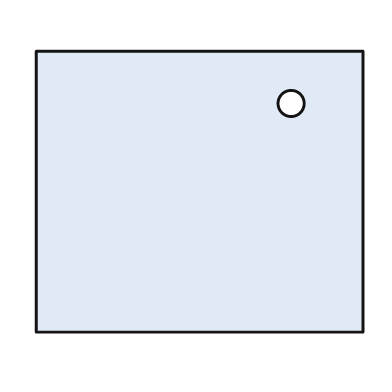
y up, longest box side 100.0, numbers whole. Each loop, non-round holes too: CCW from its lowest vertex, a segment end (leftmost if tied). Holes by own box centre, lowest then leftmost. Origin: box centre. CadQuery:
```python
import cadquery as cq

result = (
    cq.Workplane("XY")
    .moveTo(-50.0, -43.0)
    .lineTo(50.0, -43.0)
    .lineTo(50.0, 43.0)
    .lineTo(-50.0, 43.0)
    .close()
    .moveTo(28.0, 27.0)
    .circle(4.0)
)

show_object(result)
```